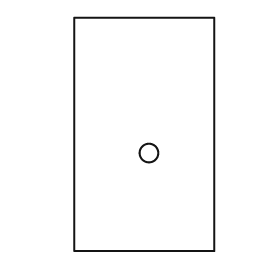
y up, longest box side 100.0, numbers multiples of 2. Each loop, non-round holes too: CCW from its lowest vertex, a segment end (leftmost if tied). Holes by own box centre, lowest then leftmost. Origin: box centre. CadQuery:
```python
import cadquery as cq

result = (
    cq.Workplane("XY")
    .moveTo(-30.0, -50.0)
    .lineTo(30.0, -50.0)
    .lineTo(30.0, 50.0)
    .lineTo(-30.0, 50.0)
    .close()
    .moveTo(2.0, -8.0)
    .circle(4.0)
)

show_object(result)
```